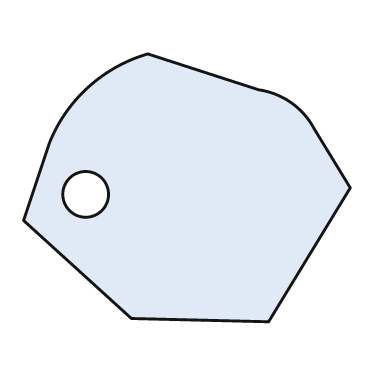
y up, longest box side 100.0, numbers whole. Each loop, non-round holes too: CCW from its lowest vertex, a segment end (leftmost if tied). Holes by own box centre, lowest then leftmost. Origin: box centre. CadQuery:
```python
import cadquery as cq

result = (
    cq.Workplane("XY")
    .moveTo(25.0, -41.0)
    .lineTo(50.0, 0.0)
    .lineTo(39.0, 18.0)
    .threePointArc((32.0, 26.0), (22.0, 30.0))
    .lineTo(-12.0, 41.0)
    .threePointArc((-30.0, 31.0), (-42.0, 14.0))
    .lineTo(-50.0, -10.0)
    .lineTo(-17.0, -40.0)
    .close()
    .moveTo(-31.0, -2.0)
    .circle(7.0)
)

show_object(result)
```